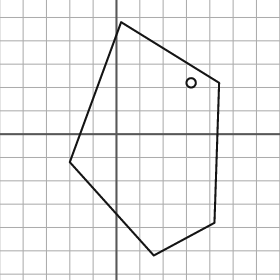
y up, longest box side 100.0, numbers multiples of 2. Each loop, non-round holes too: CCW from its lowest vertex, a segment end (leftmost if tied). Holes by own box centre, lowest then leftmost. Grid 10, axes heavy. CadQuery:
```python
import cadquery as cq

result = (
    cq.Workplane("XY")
    .moveTo(16.0, -52.0)
    .lineTo(42.0, -38.0)
    .lineTo(44.0, 22.0)
    .lineTo(2.0, 48.0)
    .lineTo(-20.0, -12.0)
    .close()
    .moveTo(32.0, 22.0)
    .circle(2.0)
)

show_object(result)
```